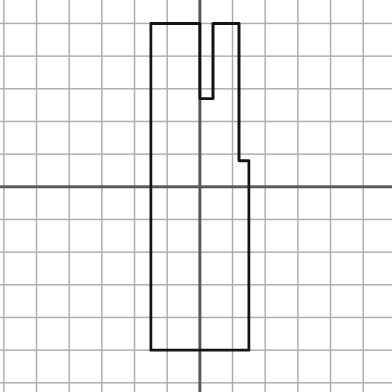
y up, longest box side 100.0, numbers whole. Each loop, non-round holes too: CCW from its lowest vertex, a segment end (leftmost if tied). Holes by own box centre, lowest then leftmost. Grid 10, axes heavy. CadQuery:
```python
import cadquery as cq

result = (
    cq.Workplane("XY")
    .moveTo(-15.0, -50.0)
    .lineTo(15.0, -50.0)
    .lineTo(15.0, 8.0)
    .lineTo(12.0, 8.0)
    .lineTo(12.0, 50.0)
    .lineTo(4.0, 50.0)
    .lineTo(4.0, 27.0)
    .lineTo(0.0, 27.0)
    .lineTo(0.0, 50.0)
    .lineTo(-15.0, 50.0)
    .close()
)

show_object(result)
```